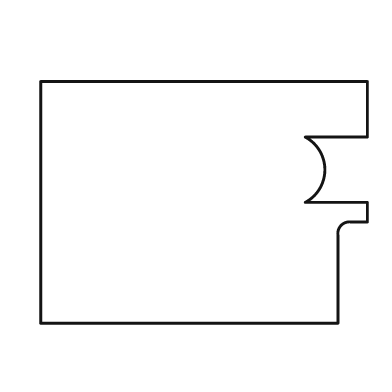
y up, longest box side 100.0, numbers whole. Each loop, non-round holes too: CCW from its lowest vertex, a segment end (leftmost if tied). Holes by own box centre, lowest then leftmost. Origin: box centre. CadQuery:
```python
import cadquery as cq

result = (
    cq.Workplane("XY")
    .moveTo(-50.0, -37.0)
    .lineTo(41.0, -37.0)
    .lineTo(41.0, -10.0)
    .threePointArc((42.0, -7.0), (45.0, -6.0))
    .lineTo(50.0, -6.0)
    .lineTo(50.0, 0.0)
    .lineTo(31.0, 0.0)
    .threePointArc((37.0, 10.0), (31.0, 20.0))
    .lineTo(50.0, 20.0)
    .lineTo(50.0, 37.0)
    .lineTo(-50.0, 37.0)
    .close()
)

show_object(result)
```